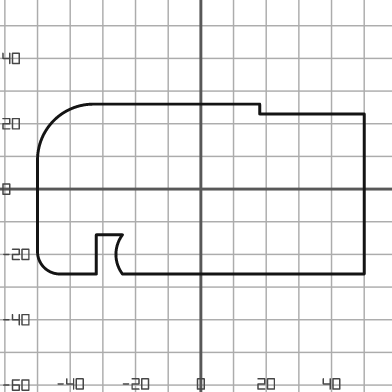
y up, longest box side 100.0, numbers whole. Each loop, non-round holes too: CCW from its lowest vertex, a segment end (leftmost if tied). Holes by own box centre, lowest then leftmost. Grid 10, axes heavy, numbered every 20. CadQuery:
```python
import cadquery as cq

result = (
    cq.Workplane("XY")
    .moveTo(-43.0, -26.0)
    .lineTo(-32.0, -26.0)
    .lineTo(-32.0, -14.0)
    .lineTo(-24.0, -14.0)
    .threePointArc((-26.0, -20.0), (-24.0, -26.0))
    .lineTo(50.0, -26.0)
    .lineTo(50.0, 23.0)
    .lineTo(18.0, 23.0)
    .lineTo(18.0, 26.0)
    .lineTo(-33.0, 26.0)
    .threePointArc((-45.0, 21.0), (-50.0, 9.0))
    .lineTo(-50.0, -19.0)
    .threePointArc((-48.0, -24.0), (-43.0, -26.0))
    .close()
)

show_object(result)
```